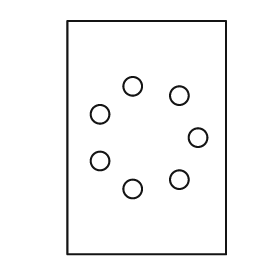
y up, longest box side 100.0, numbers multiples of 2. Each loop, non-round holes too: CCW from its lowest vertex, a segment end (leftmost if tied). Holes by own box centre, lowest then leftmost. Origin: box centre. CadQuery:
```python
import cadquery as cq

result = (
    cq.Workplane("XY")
    .moveTo(-34.0, -50.0)
    .lineTo(34.0, -50.0)
    .lineTo(34.0, 50.0)
    .lineTo(-34.0, 50.0)
    .close()
    .moveTo(-6.0, -22.0)
    .circle(4.0)
    .moveTo(14.0, -18.0)
    .circle(4.0)
    .moveTo(-20.0, -10.0)
    .circle(4.0)
    .moveTo(22.0, 0.0)
    .circle(4.0)
    .moveTo(-20.0, 10.0)
    .circle(4.0)
    .moveTo(14.0, 18.0)
    .circle(4.0)
    .moveTo(-6.0, 22.0)
    .circle(4.0)
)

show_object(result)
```